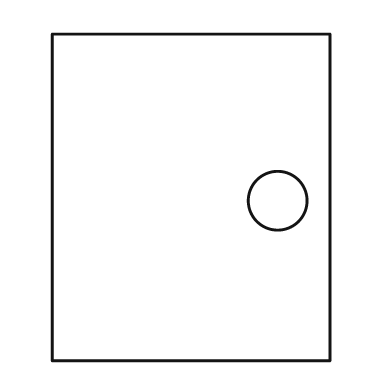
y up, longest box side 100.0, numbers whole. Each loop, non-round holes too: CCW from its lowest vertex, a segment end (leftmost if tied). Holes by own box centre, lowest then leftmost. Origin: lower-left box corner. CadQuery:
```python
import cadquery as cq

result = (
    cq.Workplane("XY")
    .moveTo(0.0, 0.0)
    .lineTo(85.0, 0.0)
    .lineTo(85.0, 100.0)
    .lineTo(0.0, 100.0)
    .close()
    .moveTo(69.0, 49.0)
    .circle(9.0)
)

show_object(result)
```